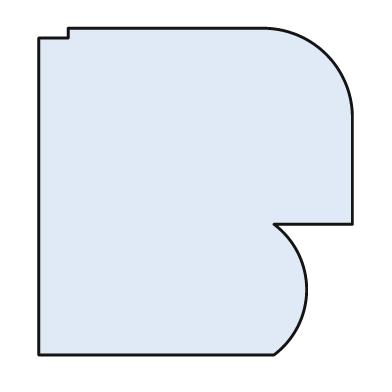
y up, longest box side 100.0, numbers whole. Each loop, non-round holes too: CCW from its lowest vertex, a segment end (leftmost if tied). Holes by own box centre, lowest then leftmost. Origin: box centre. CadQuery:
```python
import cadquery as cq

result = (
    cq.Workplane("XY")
    .moveTo(-48.0, -50.0)
    .lineTo(24.0, -50.0)
    .threePointArc((34.0, -30.0), (24.0, -10.0))
    .lineTo(48.0, -10.0)
    .lineTo(48.0, 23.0)
    .threePointArc((40.0, 42.0), (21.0, 50.0))
    .lineTo(-39.0, 50.0)
    .lineTo(-39.0, 47.0)
    .lineTo(-48.0, 47.0)
    .close()
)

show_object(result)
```